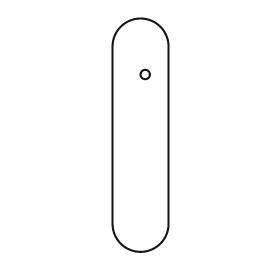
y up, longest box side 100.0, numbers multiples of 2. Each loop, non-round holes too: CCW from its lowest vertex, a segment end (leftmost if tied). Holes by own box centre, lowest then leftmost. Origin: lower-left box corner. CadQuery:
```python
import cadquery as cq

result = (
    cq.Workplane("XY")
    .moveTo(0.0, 12.0)
    .threePointArc((12.0, 0.0), (24.0, 12.0))
    .lineTo(24.0, 88.0)
    .threePointArc((12.0, 100.0), (0.0, 88.0))
    .close()
    .moveTo(14.0, 76.0)
    .circle(2.0)
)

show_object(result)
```